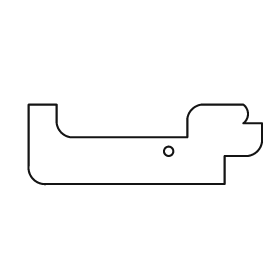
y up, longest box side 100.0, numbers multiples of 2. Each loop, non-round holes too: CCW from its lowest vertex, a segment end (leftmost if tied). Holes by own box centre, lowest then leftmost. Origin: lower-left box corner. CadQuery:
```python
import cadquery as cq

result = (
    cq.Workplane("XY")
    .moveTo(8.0, 0.0)
    .lineTo(84.0, 0.0)
    .lineTo(84.0, 12.0)
    .lineTo(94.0, 12.0)
    .threePointArc((98.0, 14.0), (100.0, 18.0))
    .lineTo(100.0, 26.0)
    .lineTo(92.0, 26.0)
    .threePointArc((94.0, 30.0), (92.0, 34.0))
    .lineTo(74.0, 34.0)
    .threePointArc((70.0, 32.0), (68.0, 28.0))
    .lineTo(68.0, 20.0)
    .lineTo(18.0, 20.0)
    .threePointArc((14.0, 22.0), (12.0, 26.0))
    .lineTo(12.0, 34.0)
    .lineTo(0.0, 34.0)
    .lineTo(0.0, 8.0)
    .threePointArc((2.0, 2.0), (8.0, 0.0))
    .close()
    .moveTo(60.0, 14.0)
    .circle(2.0)
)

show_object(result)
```